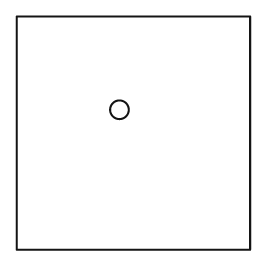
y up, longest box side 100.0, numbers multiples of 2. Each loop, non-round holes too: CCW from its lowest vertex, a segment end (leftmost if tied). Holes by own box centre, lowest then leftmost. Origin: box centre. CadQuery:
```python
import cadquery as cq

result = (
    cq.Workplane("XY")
    .moveTo(-50.0, -50.0)
    .lineTo(50.0, -50.0)
    .lineTo(50.0, 50.0)
    .lineTo(-50.0, 50.0)
    .close()
    .moveTo(-6.0, 10.0)
    .circle(4.0)
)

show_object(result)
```